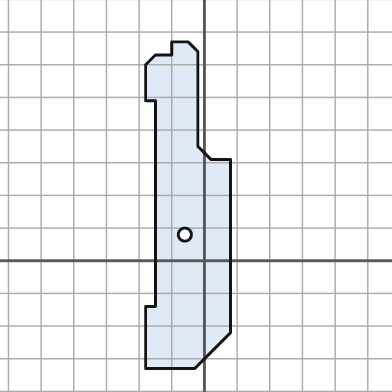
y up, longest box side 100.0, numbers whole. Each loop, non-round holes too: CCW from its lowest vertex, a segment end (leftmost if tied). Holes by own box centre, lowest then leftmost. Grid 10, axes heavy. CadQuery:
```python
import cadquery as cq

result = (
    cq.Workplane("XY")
    .moveTo(-18.0, -33.0)
    .lineTo(-3.0, -33.0)
    .lineTo(8.0, -22.0)
    .lineTo(8.0, 31.0)
    .lineTo(2.0, 31.0)
    .lineTo(-2.0, 35.0)
    .lineTo(-2.0, 64.0)
    .lineTo(-5.0, 67.0)
    .lineTo(-10.0, 67.0)
    .lineTo(-10.0, 63.0)
    .lineTo(-15.0, 63.0)
    .lineTo(-18.0, 60.0)
    .lineTo(-18.0, 49.0)
    .lineTo(-15.0, 49.0)
    .lineTo(-15.0, -14.0)
    .lineTo(-18.0, -14.0)
    .close()
    .moveTo(-6.0, 8.0)
    .circle(2.0)
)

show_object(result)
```